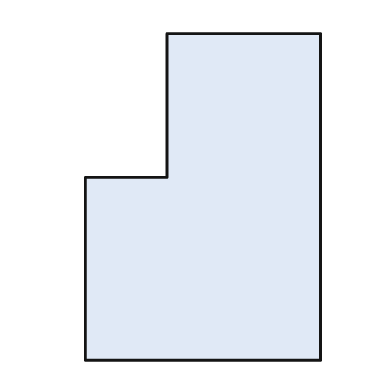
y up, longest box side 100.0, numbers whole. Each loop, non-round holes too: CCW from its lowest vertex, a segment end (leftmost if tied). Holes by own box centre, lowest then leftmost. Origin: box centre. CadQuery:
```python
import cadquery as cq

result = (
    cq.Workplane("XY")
    .moveTo(-36.0, -50.0)
    .lineTo(36.0, -50.0)
    .lineTo(36.0, 50.0)
    .lineTo(-11.0, 50.0)
    .lineTo(-11.0, 6.0)
    .lineTo(-36.0, 6.0)
    .close()
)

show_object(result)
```